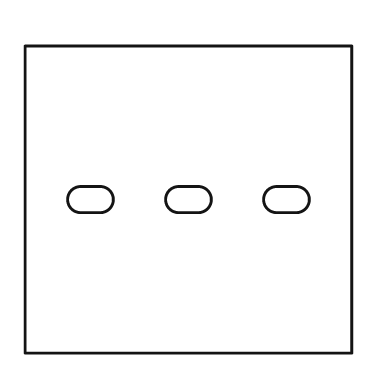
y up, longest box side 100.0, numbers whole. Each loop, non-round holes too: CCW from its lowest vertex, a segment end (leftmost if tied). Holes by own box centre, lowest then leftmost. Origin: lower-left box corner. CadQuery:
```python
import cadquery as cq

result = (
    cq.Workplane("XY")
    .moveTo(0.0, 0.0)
    .lineTo(100.0, 0.0)
    .lineTo(100.0, 94.0)
    .lineTo(0.0, 94.0)
    .close()
    .moveTo(17.0, 43.0)
    .lineTo(23.0, 43.0)
    .threePointArc((27.0, 47.0), (23.0, 51.0))
    .lineTo(17.0, 51.0)
    .threePointArc((13.0, 47.0), (17.0, 43.0))
    .close()
    .moveTo(47.0, 43.0)
    .lineTo(53.0, 43.0)
    .threePointArc((57.0, 47.0), (53.0, 51.0))
    .lineTo(47.0, 51.0)
    .threePointArc((43.0, 47.0), (47.0, 43.0))
    .close()
    .moveTo(77.0, 43.0)
    .lineTo(83.0, 43.0)
    .threePointArc((87.0, 47.0), (83.0, 51.0))
    .lineTo(77.0, 51.0)
    .threePointArc((73.0, 47.0), (77.0, 43.0))
    .close()
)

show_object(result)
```